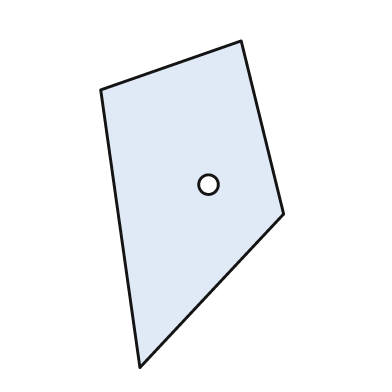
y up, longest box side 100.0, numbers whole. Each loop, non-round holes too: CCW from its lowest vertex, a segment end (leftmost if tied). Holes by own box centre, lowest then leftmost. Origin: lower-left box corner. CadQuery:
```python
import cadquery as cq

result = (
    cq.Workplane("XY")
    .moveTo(12.0, 0.0)
    .lineTo(56.0, 47.0)
    .lineTo(43.0, 100.0)
    .lineTo(0.0, 85.0)
    .close()
    .moveTo(33.0, 56.0)
    .circle(3.0)
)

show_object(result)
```